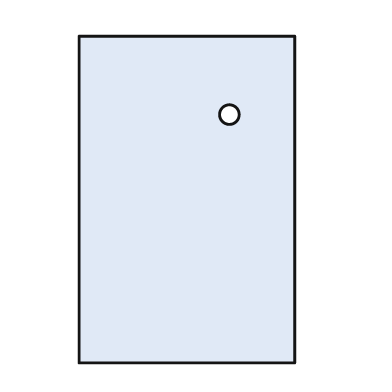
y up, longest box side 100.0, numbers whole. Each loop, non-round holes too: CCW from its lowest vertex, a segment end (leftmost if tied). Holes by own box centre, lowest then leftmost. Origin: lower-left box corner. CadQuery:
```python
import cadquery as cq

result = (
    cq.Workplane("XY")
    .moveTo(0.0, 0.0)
    .lineTo(66.0, 0.0)
    .lineTo(66.0, 100.0)
    .lineTo(0.0, 100.0)
    .close()
    .moveTo(46.0, 76.0)
    .circle(3.0)
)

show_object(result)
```